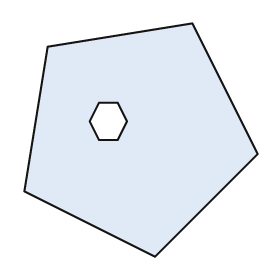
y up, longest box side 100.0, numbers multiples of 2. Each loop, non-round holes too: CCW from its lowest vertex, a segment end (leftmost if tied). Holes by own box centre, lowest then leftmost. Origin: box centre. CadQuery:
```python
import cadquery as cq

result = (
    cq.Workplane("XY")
    .moveTo(6.0, -50.0)
    .lineTo(50.0, -6.0)
    .lineTo(22.0, 50.0)
    .lineTo(-40.0, 40.0)
    .lineTo(-50.0, -22.0)
    .close()
    .moveTo(-18.0, 0.0)
    .lineTo(-10.0, 0.0)
    .lineTo(-6.0, 8.0)
    .lineTo(-10.0, 16.0)
    .lineTo(-18.0, 16.0)
    .lineTo(-22.0, 8.0)
    .close()
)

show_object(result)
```